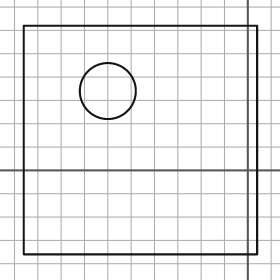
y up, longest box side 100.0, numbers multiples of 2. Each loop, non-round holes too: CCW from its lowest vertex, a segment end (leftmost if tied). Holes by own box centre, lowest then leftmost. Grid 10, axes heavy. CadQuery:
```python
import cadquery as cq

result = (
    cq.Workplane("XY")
    .moveTo(-96.0, -36.0)
    .lineTo(4.0, -36.0)
    .lineTo(4.0, 62.0)
    .lineTo(-96.0, 62.0)
    .close()
    .moveTo(-60.0, 34.0)
    .circle(12.0)
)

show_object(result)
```